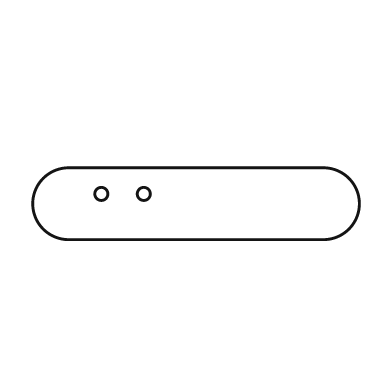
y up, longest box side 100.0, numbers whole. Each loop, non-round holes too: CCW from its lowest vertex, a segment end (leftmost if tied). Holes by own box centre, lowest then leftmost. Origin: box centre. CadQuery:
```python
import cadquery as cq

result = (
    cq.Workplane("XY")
    .moveTo(-39.0, -11.0)
    .lineTo(39.0, -11.0)
    .threePointArc((50.0, 0.0), (39.0, 11.0))
    .lineTo(-39.0, 11.0)
    .threePointArc((-50.0, 0.0), (-39.0, -11.0))
    .close()
    .moveTo(-29.0, 3.0)
    .circle(2.0)
    .moveTo(-16.0, 3.0)
    .circle(2.0)
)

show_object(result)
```